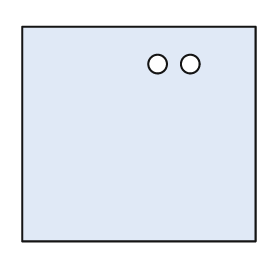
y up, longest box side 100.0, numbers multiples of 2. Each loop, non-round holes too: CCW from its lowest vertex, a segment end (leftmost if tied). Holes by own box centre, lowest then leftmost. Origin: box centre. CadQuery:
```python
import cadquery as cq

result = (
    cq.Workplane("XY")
    .moveTo(-50.0, -46.0)
    .lineTo(50.0, -46.0)
    .lineTo(50.0, 46.0)
    .lineTo(-50.0, 46.0)
    .close()
    .moveTo(8.0, 30.0)
    .circle(4.0)
    .moveTo(22.0, 30.0)
    .circle(4.0)
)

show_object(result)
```